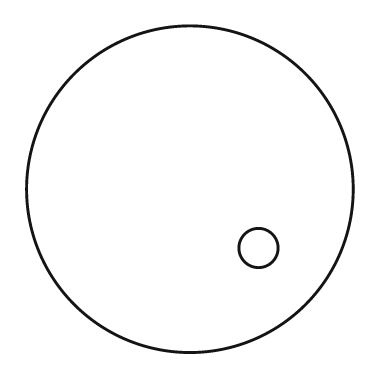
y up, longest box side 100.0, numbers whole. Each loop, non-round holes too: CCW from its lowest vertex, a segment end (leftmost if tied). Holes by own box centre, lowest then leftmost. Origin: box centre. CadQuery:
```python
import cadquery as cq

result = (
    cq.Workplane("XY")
    .moveTo(0.0, 0.0)
    .circle(50.0)
    .moveTo(21.0, -18.0)
    .circle(6.0)
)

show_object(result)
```